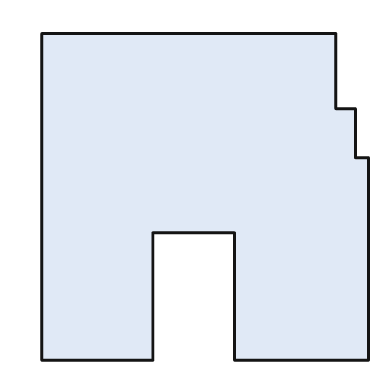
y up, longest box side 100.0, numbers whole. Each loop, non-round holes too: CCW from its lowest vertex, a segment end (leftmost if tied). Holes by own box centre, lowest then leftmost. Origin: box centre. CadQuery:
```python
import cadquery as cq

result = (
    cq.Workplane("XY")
    .moveTo(-50.0, -50.0)
    .lineTo(-16.0, -50.0)
    .lineTo(-16.0, -11.0)
    .lineTo(9.0, -11.0)
    .lineTo(9.0, -50.0)
    .lineTo(50.0, -50.0)
    .lineTo(50.0, 12.0)
    .lineTo(46.0, 12.0)
    .lineTo(46.0, 27.0)
    .lineTo(40.0, 27.0)
    .lineTo(40.0, 50.0)
    .lineTo(-50.0, 50.0)
    .close()
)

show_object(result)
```